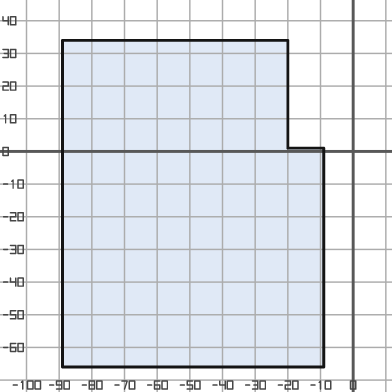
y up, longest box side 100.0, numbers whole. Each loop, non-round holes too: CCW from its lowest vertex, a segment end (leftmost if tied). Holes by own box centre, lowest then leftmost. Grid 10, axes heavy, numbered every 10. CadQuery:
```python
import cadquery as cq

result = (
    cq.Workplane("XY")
    .moveTo(-89.0, -66.0)
    .lineTo(-9.0, -66.0)
    .lineTo(-9.0, 1.0)
    .lineTo(-20.0, 1.0)
    .lineTo(-20.0, 34.0)
    .lineTo(-89.0, 34.0)
    .close()
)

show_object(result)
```